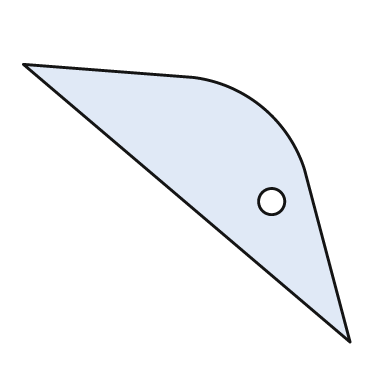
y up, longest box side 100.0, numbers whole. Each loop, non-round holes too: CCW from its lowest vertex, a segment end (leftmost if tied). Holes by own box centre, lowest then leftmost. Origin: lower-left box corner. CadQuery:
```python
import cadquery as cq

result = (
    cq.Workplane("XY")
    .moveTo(100.0, 0.0)
    .lineTo(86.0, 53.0)
    .threePointArc((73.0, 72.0), (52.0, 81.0))
    .lineTo(0.0, 85.0)
    .close()
    .moveTo(76.0, 43.0)
    .circle(4.0)
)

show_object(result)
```